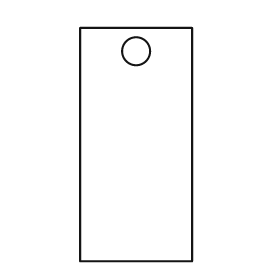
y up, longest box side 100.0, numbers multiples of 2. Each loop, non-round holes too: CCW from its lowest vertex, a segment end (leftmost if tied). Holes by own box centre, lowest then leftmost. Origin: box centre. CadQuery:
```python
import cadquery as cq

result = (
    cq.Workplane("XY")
    .moveTo(-24.0, -50.0)
    .lineTo(24.0, -50.0)
    .lineTo(24.0, 50.0)
    .lineTo(-24.0, 50.0)
    .close()
    .moveTo(0.0, 40.0)
    .circle(6.0)
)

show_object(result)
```